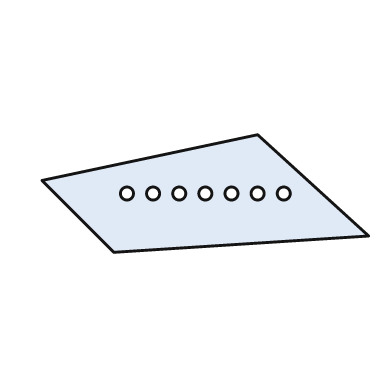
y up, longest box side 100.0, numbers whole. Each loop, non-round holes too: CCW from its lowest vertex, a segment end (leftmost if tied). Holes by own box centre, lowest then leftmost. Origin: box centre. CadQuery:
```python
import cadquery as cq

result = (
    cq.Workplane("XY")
    .moveTo(-28.0, -18.0)
    .lineTo(50.0, -13.0)
    .lineTo(16.0, 18.0)
    .lineTo(-50.0, 4.0)
    .close()
    .moveTo(-24.0, 0.0)
    .circle(2.0)
    .moveTo(-16.0, 0.0)
    .circle(2.0)
    .moveTo(-8.0, 0.0)
    .circle(2.0)
    .moveTo(0.0, 0.0)
    .circle(2.0)
    .moveTo(8.0, 0.0)
    .circle(2.0)
    .moveTo(16.0, 0.0)
    .circle(2.0)
    .moveTo(24.0, 0.0)
    .circle(2.0)
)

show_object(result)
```